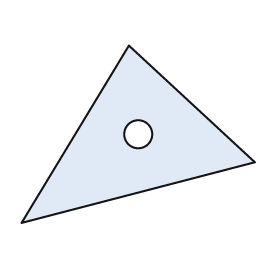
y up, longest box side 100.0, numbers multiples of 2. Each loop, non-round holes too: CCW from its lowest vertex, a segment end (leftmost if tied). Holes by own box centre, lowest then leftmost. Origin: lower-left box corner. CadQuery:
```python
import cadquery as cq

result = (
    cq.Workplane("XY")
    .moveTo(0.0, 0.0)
    .lineTo(100.0, 26.0)
    .lineTo(46.0, 76.0)
    .close()
    .moveTo(50.0, 38.0)
    .circle(6.0)
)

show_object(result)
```